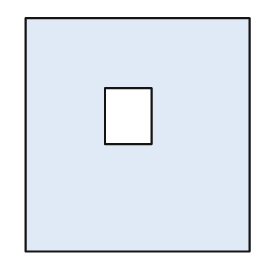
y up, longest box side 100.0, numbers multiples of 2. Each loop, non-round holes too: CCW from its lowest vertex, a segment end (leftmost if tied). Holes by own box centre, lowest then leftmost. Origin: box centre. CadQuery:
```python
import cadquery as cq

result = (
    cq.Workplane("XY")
    .moveTo(-48.0, -50.0)
    .lineTo(48.0, -50.0)
    .lineTo(48.0, 50.0)
    .lineTo(-48.0, 50.0)
    .close()
    .moveTo(-14.0, -4.0)
    .lineTo(6.0, -4.0)
    .lineTo(6.0, 20.0)
    .lineTo(-14.0, 20.0)
    .close()
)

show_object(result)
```